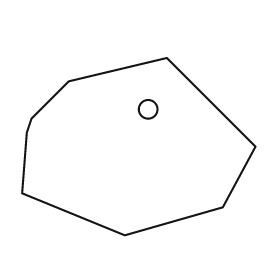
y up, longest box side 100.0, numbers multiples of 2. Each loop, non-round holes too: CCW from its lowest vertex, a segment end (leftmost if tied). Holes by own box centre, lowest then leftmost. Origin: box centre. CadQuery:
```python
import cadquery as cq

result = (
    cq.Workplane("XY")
    .moveTo(-6.0, -38.0)
    .lineTo(36.0, -26.0)
    .lineTo(50.0, 0.0)
    .lineTo(12.0, 38.0)
    .lineTo(-30.0, 28.0)
    .lineTo(-46.0, 12.0)
    .lineTo(-48.0, 6.0)
    .lineTo(-50.0, -20.0)
    .close()
    .moveTo(4.0, 16.0)
    .circle(4.0)
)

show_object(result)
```